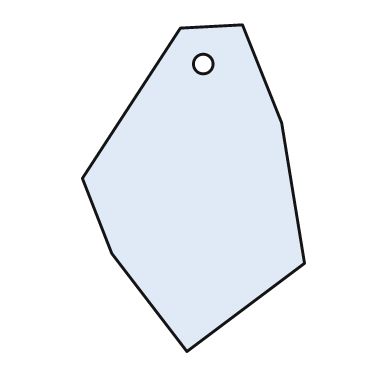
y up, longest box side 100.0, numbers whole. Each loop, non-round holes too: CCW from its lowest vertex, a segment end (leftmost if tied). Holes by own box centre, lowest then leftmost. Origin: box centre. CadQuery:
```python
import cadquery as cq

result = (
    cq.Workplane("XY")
    .moveTo(-2.0, -50.0)
    .lineTo(34.0, -23.0)
    .lineTo(27.0, 20.0)
    .lineTo(15.0, 50.0)
    .lineTo(-4.0, 49.0)
    .lineTo(-34.0, 3.0)
    .lineTo(-25.0, -20.0)
    .close()
    .moveTo(3.0, 38.0)
    .circle(3.0)
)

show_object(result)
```